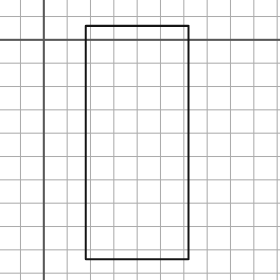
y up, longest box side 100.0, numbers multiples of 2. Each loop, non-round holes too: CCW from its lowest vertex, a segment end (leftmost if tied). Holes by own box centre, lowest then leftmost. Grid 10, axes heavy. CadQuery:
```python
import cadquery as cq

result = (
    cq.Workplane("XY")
    .moveTo(18.0, -94.0)
    .lineTo(62.0, -94.0)
    .lineTo(62.0, 6.0)
    .lineTo(18.0, 6.0)
    .close()
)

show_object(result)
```